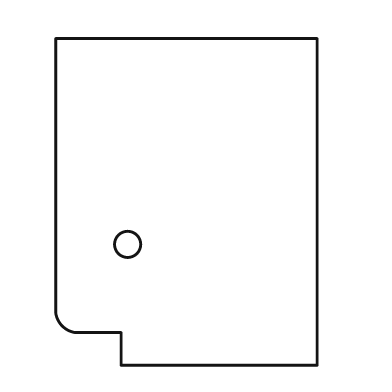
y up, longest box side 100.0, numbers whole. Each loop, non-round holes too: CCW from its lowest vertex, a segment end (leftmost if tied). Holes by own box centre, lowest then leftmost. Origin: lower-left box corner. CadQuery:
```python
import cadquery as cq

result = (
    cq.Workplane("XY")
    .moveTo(20.0, 0.0)
    .lineTo(80.0, 0.0)
    .lineTo(80.0, 100.0)
    .lineTo(0.0, 100.0)
    .lineTo(0.0, 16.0)
    .threePointArc((2.0, 12.0), (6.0, 10.0))
    .lineTo(20.0, 10.0)
    .close()
    .moveTo(22.0, 37.0)
    .circle(4.0)
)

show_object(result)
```